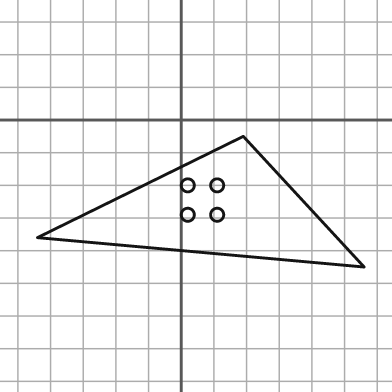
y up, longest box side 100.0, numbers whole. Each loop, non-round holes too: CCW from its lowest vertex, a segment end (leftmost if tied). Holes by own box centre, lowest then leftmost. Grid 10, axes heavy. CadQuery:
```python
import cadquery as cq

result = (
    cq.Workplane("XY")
    .moveTo(56.0, -45.0)
    .lineTo(19.0, -5.0)
    .lineTo(-44.0, -36.0)
    .close()
    .moveTo(2.0, -29.0)
    .circle(2.0)
    .moveTo(11.0, -29.0)
    .circle(2.0)
    .moveTo(2.0, -20.0)
    .circle(2.0)
    .moveTo(11.0, -20.0)
    .circle(2.0)
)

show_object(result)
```